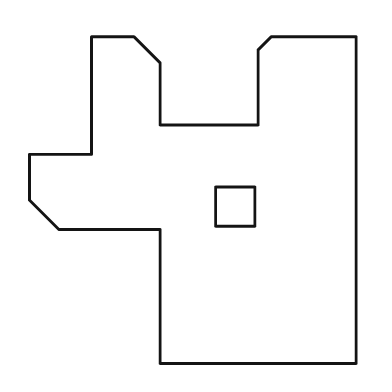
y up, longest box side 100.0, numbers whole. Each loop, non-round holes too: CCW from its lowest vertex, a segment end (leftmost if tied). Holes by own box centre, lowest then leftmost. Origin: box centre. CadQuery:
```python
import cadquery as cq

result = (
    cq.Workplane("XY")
    .moveTo(-10.0, -50.0)
    .lineTo(50.0, -50.0)
    .lineTo(50.0, 50.0)
    .lineTo(24.0, 50.0)
    .lineTo(20.0, 46.0)
    .lineTo(20.0, 23.0)
    .lineTo(-10.0, 23.0)
    .lineTo(-10.0, 42.0)
    .lineTo(-18.0, 50.0)
    .lineTo(-31.0, 50.0)
    .lineTo(-31.0, 14.0)
    .lineTo(-50.0, 14.0)
    .lineTo(-50.0, 0.0)
    .lineTo(-41.0, -9.0)
    .lineTo(-10.0, -9.0)
    .close()
    .moveTo(7.0, -8.0)
    .lineTo(19.0, -8.0)
    .lineTo(19.0, 4.0)
    .lineTo(7.0, 4.0)
    .close()
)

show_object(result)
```